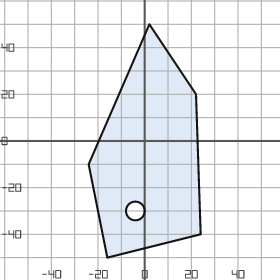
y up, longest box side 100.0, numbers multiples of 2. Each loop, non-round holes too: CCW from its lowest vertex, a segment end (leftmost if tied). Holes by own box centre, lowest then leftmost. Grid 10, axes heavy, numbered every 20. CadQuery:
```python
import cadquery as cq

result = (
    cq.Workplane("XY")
    .moveTo(-16.0, -50.0)
    .lineTo(24.0, -40.0)
    .lineTo(22.0, 20.0)
    .lineTo(2.0, 50.0)
    .lineTo(-24.0, -10.0)
    .close()
    .moveTo(-4.0, -30.0)
    .circle(4.0)
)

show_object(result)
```